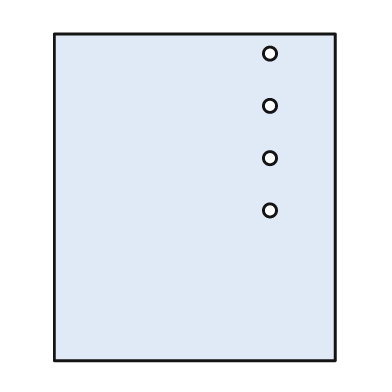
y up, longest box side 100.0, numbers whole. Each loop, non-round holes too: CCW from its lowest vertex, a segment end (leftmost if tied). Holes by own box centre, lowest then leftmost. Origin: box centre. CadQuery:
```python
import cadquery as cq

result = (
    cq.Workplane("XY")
    .moveTo(-43.0, -50.0)
    .lineTo(43.0, -50.0)
    .lineTo(43.0, 50.0)
    .lineTo(-43.0, 50.0)
    .close()
    .moveTo(23.0, -4.0)
    .circle(2.0)
    .moveTo(23.0, 12.0)
    .circle(2.0)
    .moveTo(23.0, 28.0)
    .circle(2.0)
    .moveTo(23.0, 44.0)
    .circle(2.0)
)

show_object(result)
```